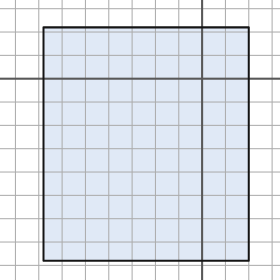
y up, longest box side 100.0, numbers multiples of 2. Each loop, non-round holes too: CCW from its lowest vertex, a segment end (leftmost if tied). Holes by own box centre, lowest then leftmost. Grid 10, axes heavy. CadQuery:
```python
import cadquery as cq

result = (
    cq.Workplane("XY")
    .moveTo(-68.0, -78.0)
    .lineTo(20.0, -78.0)
    .lineTo(20.0, 22.0)
    .lineTo(-68.0, 22.0)
    .close()
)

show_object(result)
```